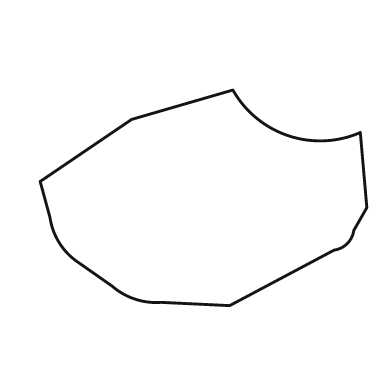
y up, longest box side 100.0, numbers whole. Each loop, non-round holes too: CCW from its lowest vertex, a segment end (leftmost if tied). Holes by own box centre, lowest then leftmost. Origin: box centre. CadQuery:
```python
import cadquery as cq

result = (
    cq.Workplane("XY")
    .moveTo(8.0, -33.0)
    .lineTo(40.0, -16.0)
    .threePointArc((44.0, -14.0), (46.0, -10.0))
    .lineTo(50.0, -3.0)
    .lineTo(48.0, 20.0)
    .threePointArc((26.0, 19.0), (9.0, 33.0))
    .lineTo(-22.0, 24.0)
    .lineTo(-50.0, 5.0)
    .lineTo(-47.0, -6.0)
    .threePointArc((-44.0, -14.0), (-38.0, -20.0))
    .lineTo(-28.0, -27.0)
    .threePointArc((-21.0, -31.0), (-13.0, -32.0))
    .close()
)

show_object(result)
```